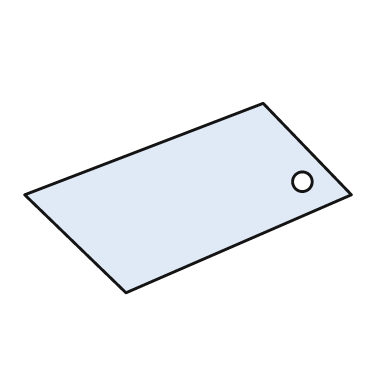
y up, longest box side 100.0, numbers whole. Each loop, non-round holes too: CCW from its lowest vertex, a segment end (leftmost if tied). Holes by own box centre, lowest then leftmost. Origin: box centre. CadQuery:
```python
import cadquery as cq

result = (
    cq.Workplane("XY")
    .moveTo(-19.0, -29.0)
    .lineTo(50.0, 1.0)
    .lineTo(23.0, 29.0)
    .lineTo(-50.0, 1.0)
    .close()
    .moveTo(35.0, 5.0)
    .circle(3.0)
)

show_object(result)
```